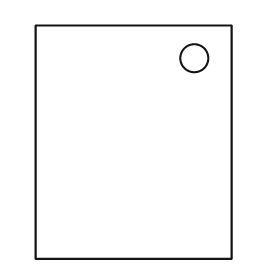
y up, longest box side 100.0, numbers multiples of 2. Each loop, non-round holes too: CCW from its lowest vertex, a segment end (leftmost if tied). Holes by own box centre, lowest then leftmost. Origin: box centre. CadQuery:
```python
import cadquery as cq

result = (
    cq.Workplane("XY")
    .moveTo(-42.0, -50.0)
    .lineTo(42.0, -50.0)
    .lineTo(42.0, 50.0)
    .lineTo(-42.0, 50.0)
    .close()
    .moveTo(26.0, 36.0)
    .circle(6.0)
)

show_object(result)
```